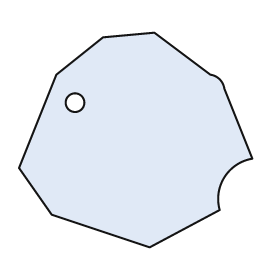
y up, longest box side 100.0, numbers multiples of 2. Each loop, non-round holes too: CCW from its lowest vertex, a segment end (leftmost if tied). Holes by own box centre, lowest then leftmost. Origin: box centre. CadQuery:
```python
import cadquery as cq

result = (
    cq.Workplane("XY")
    .moveTo(6.0, -46.0)
    .lineTo(36.0, -30.0)
    .threePointArc((38.0, -16.0), (50.0, -8.0))
    .lineTo(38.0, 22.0)
    .threePointArc((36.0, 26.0), (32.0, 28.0))
    .lineTo(8.0, 46.0)
    .lineTo(-14.0, 44.0)
    .lineTo(-34.0, 28.0)
    .lineTo(-50.0, -12.0)
    .lineTo(-36.0, -32.0)
    .close()
    .moveTo(-26.0, 16.0)
    .circle(4.0)
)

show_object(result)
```